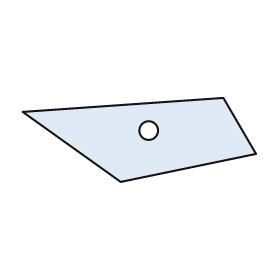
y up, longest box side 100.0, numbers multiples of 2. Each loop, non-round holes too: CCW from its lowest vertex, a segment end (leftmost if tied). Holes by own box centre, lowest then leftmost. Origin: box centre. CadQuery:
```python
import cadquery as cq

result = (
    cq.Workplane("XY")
    .moveTo(-8.0, -18.0)
    .lineTo(50.0, -6.0)
    .lineTo(36.0, 18.0)
    .lineTo(-50.0, 12.0)
    .close()
    .moveTo(4.0, 4.0)
    .circle(4.0)
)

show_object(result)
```